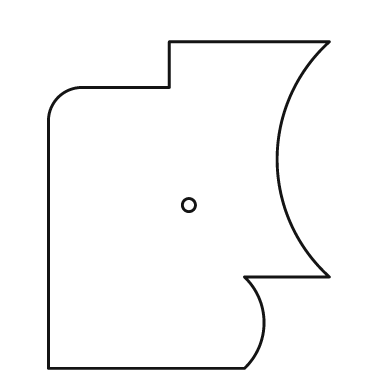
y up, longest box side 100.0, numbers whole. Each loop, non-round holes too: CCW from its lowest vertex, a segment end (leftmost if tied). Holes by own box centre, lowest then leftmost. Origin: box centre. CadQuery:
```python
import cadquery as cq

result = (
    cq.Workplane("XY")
    .moveTo(-43.0, -50.0)
    .lineTo(17.0, -50.0)
    .threePointArc((23.0, -36.0), (17.0, -22.0))
    .lineTo(43.0, -22.0)
    .threePointArc((27.0, 14.0), (43.0, 50.0))
    .lineTo(-6.0, 50.0)
    .lineTo(-6.0, 36.0)
    .lineTo(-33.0, 36.0)
    .threePointArc((-40.0, 33.0), (-43.0, 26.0))
    .close()
    .moveTo(0.0, 0.0)
    .circle(2.0)
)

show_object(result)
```